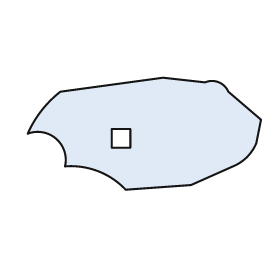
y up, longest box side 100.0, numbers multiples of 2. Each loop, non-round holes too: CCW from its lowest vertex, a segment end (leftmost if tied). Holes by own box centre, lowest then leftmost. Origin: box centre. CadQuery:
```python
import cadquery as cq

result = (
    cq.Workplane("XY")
    .moveTo(-8.0, -24.0)
    .lineTo(20.0, -22.0)
    .lineTo(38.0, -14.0)
    .threePointArc((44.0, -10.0), (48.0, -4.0))
    .lineTo(50.0, 6.0)
    .lineTo(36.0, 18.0)
    .threePointArc((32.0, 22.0), (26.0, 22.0))
    .lineTo(8.0, 24.0)
    .lineTo(-36.0, 18.0)
    .threePointArc((-44.0, 10.0), (-50.0, 0.0))
    .threePointArc((-38.0, -2.0), (-34.0, -14.0))
    .threePointArc((-20.0, -16.0), (-8.0, -24.0))
    .close()
    .moveTo(-14.0, -6.0)
    .lineTo(-6.0, -6.0)
    .lineTo(-6.0, 2.0)
    .lineTo(-14.0, 2.0)
    .close()
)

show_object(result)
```